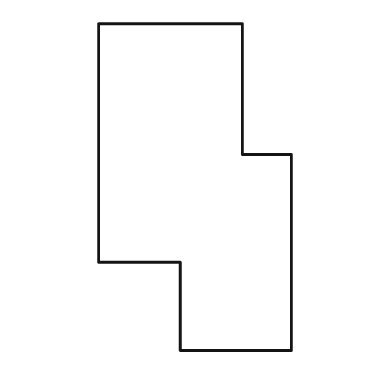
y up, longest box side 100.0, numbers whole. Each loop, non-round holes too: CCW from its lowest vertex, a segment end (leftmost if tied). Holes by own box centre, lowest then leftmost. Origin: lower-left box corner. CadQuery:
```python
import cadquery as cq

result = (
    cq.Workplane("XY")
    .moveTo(25.0, 0.0)
    .lineTo(59.0, 0.0)
    .lineTo(59.0, 60.0)
    .lineTo(44.0, 60.0)
    .lineTo(44.0, 100.0)
    .lineTo(0.0, 100.0)
    .lineTo(0.0, 27.0)
    .lineTo(25.0, 27.0)
    .close()
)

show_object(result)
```